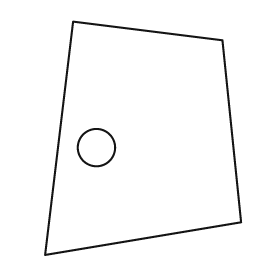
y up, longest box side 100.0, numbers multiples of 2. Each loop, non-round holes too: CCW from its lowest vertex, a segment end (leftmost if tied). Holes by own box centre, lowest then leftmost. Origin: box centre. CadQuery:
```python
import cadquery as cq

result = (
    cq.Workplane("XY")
    .moveTo(-42.0, -50.0)
    .lineTo(42.0, -36.0)
    .lineTo(34.0, 42.0)
    .lineTo(-30.0, 50.0)
    .close()
    .moveTo(-20.0, -4.0)
    .circle(8.0)
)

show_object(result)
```